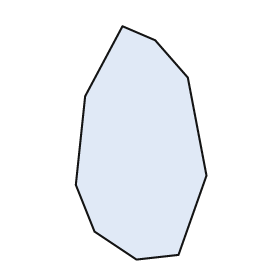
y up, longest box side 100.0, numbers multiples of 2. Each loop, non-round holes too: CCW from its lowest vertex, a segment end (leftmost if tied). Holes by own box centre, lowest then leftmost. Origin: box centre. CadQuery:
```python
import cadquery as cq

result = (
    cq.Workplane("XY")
    .moveTo(-2.0, -50.0)
    .lineTo(16.0, -48.0)
    .lineTo(28.0, -14.0)
    .lineTo(20.0, 28.0)
    .lineTo(6.0, 44.0)
    .lineTo(-8.0, 50.0)
    .lineTo(-24.0, 20.0)
    .lineTo(-28.0, -18.0)
    .lineTo(-20.0, -38.0)
    .close()
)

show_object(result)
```